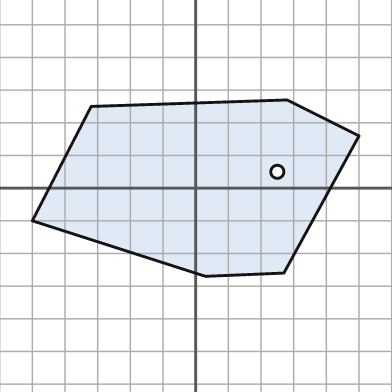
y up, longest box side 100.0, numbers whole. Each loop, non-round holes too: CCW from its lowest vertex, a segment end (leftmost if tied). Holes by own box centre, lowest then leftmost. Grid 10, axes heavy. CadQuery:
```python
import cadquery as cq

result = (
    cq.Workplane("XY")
    .moveTo(3.0, -27.0)
    .lineTo(27.0, -26.0)
    .lineTo(50.0, 16.0)
    .lineTo(28.0, 27.0)
    .lineTo(-32.0, 25.0)
    .lineTo(-50.0, -10.0)
    .close()
    .moveTo(25.0, 5.0)
    .circle(2.0)
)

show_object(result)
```